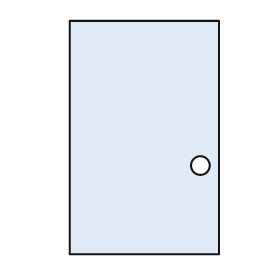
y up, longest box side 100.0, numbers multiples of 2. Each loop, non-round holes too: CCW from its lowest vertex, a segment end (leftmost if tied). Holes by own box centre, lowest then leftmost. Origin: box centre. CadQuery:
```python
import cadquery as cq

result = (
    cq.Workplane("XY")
    .moveTo(-32.0, -50.0)
    .lineTo(32.0, -50.0)
    .lineTo(32.0, 50.0)
    .lineTo(-32.0, 50.0)
    .close()
    .moveTo(24.0, -12.0)
    .circle(4.0)
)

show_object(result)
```